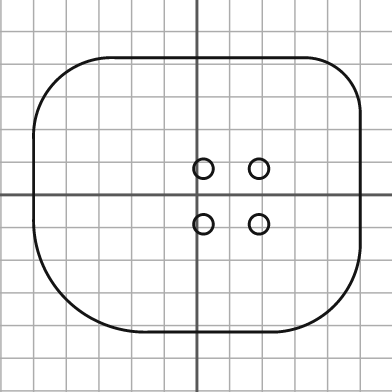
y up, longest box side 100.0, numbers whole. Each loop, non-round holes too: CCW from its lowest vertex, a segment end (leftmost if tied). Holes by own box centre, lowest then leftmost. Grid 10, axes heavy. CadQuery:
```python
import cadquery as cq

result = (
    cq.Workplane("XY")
    .moveTo(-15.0, -42.0)
    .lineTo(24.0, -42.0)
    .threePointArc((42.0, -34.0), (50.0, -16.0))
    .lineTo(50.0, 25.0)
    .threePointArc((45.0, 37.0), (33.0, 42.0))
    .lineTo(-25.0, 42.0)
    .threePointArc((-43.0, 35.0), (-50.0, 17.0))
    .lineTo(-50.0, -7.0)
    .threePointArc((-40.0, -32.0), (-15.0, -42.0))
    .close()
    .moveTo(2.0, -9.0)
    .circle(3.0)
    .moveTo(19.0, -9.0)
    .circle(3.0)
    .moveTo(2.0, 8.0)
    .circle(3.0)
    .moveTo(19.0, 8.0)
    .circle(3.0)
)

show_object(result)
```